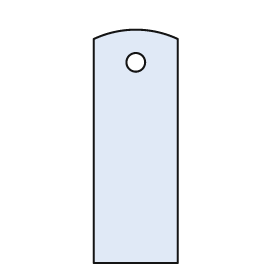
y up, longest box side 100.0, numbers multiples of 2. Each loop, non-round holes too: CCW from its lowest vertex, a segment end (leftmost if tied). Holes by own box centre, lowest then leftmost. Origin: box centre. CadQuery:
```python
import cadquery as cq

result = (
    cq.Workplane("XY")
    .moveTo(-18.0, -50.0)
    .lineTo(18.0, -50.0)
    .lineTo(18.0, 46.0)
    .threePointArc((0.0, 50.0), (-18.0, 46.0))
    .close()
    .moveTo(0.0, 36.0)
    .circle(4.0)
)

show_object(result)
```